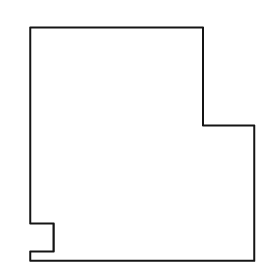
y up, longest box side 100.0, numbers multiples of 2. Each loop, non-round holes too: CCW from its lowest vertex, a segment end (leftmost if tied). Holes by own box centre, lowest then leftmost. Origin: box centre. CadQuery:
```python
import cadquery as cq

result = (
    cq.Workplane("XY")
    .moveTo(-48.0, -50.0)
    .lineTo(48.0, -50.0)
    .lineTo(48.0, 8.0)
    .lineTo(26.0, 8.0)
    .lineTo(26.0, 50.0)
    .lineTo(-48.0, 50.0)
    .lineTo(-48.0, -34.0)
    .lineTo(-38.0, -34.0)
    .lineTo(-38.0, -46.0)
    .lineTo(-48.0, -46.0)
    .close()
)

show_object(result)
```